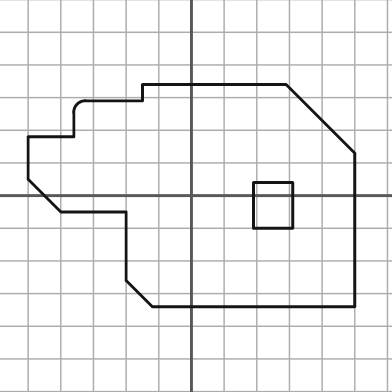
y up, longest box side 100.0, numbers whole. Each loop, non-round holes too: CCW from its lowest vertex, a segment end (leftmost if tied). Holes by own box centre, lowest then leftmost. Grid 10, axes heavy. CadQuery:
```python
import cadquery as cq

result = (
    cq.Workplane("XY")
    .moveTo(-12.0, -34.0)
    .lineTo(50.0, -34.0)
    .lineTo(50.0, 13.0)
    .lineTo(29.0, 34.0)
    .lineTo(-15.0, 34.0)
    .lineTo(-15.0, 29.0)
    .lineTo(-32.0, 29.0)
    .threePointArc((-35.0, 28.0), (-36.0, 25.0))
    .lineTo(-36.0, 18.0)
    .lineTo(-50.0, 18.0)
    .lineTo(-50.0, 5.0)
    .lineTo(-40.0, -5.0)
    .lineTo(-20.0, -5.0)
    .lineTo(-20.0, -26.0)
    .close()
    .moveTo(19.0, -10.0)
    .lineTo(31.0, -10.0)
    .lineTo(31.0, 4.0)
    .lineTo(19.0, 4.0)
    .close()
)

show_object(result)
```